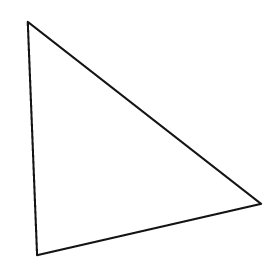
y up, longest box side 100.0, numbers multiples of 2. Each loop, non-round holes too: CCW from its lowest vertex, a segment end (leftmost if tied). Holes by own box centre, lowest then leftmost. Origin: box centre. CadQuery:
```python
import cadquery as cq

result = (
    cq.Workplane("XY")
    .moveTo(-46.0, -50.0)
    .lineTo(50.0, -28.0)
    .lineTo(-50.0, 50.0)
    .close()
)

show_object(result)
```